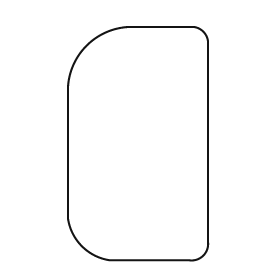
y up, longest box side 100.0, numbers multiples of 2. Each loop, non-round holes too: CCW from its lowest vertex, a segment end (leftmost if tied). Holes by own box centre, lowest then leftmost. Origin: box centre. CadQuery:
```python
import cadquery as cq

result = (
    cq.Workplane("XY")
    .moveTo(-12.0, -50.0)
    .lineTo(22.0, -50.0)
    .threePointArc((28.0, -48.0), (30.0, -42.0))
    .lineTo(30.0, 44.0)
    .threePointArc((28.0, 48.0), (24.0, 50.0))
    .lineTo(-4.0, 50.0)
    .threePointArc((-22.0, 42.0), (-30.0, 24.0))
    .lineTo(-30.0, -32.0)
    .threePointArc((-24.0, -44.0), (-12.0, -50.0))
    .close()
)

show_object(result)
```